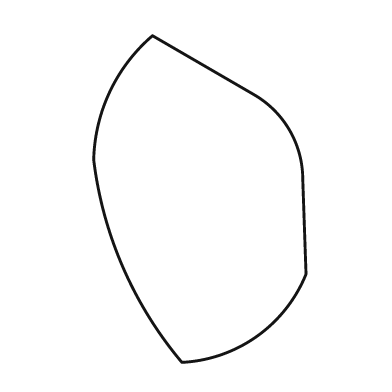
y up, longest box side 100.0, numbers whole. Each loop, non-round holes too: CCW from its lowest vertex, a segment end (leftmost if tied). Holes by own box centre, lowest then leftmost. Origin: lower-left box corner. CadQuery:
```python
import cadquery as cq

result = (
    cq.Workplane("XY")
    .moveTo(27.0, 0.0)
    .threePointArc((50.0, 8.0), (65.0, 27.0))
    .lineTo(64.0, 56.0)
    .threePointArc((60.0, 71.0), (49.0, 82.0))
    .lineTo(18.0, 100.0)
    .threePointArc((5.0, 83.0), (0.0, 62.0))
    .threePointArc((9.0, 29.0), (27.0, 0.0))
    .close()
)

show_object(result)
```